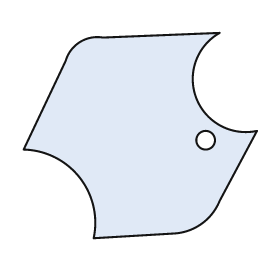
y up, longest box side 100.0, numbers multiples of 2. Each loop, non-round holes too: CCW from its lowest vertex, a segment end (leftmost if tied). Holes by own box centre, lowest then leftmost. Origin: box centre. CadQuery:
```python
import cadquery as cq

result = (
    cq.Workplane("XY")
    .moveTo(-20.0, -44.0)
    .lineTo(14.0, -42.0)
    .threePointArc((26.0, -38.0), (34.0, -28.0))
    .lineTo(50.0, 2.0)
    .threePointArc((24.0, 16.0), (34.0, 44.0))
    .lineTo(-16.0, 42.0)
    .threePointArc((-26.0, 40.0), (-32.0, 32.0))
    .lineTo(-50.0, -6.0)
    .threePointArc((-26.0, -18.0), (-20.0, -44.0))
    .close()
    .moveTo(28.0, -2.0)
    .circle(4.0)
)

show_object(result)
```